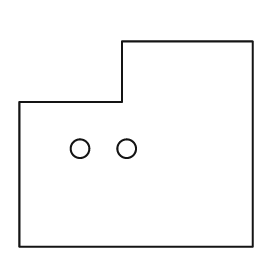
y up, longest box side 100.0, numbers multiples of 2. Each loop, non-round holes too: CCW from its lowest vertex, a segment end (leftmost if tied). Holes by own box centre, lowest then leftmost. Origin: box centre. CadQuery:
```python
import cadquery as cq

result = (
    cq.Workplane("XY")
    .moveTo(-50.0, -44.0)
    .lineTo(50.0, -44.0)
    .lineTo(50.0, 44.0)
    .lineTo(-6.0, 44.0)
    .lineTo(-6.0, 18.0)
    .lineTo(-50.0, 18.0)
    .close()
    .moveTo(-24.0, -2.0)
    .circle(4.0)
    .moveTo(-4.0, -2.0)
    .circle(4.0)
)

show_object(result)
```